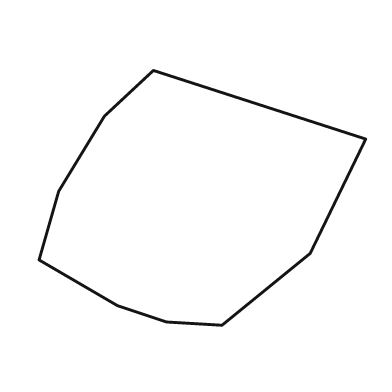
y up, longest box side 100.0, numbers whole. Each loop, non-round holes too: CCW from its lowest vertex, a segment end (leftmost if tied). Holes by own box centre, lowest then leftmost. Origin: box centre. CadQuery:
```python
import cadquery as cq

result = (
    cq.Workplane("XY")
    .moveTo(6.0, -39.0)
    .lineTo(33.0, -17.0)
    .lineTo(50.0, 18.0)
    .lineTo(-15.0, 39.0)
    .lineTo(-30.0, 25.0)
    .lineTo(-44.0, 2.0)
    .lineTo(-50.0, -19.0)
    .lineTo(-26.0, -33.0)
    .lineTo(-11.0, -38.0)
    .close()
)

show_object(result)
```